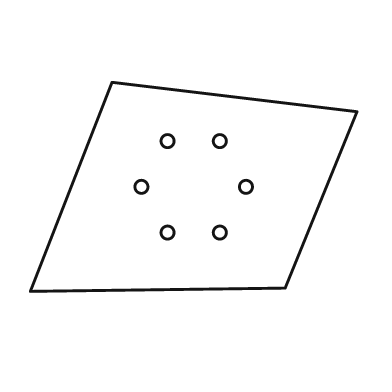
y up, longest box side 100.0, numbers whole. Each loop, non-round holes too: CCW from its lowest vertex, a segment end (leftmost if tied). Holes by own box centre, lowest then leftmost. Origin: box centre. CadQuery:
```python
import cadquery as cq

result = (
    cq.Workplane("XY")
    .moveTo(-50.0, -32.0)
    .lineTo(28.0, -31.0)
    .lineTo(50.0, 23.0)
    .lineTo(-25.0, 32.0)
    .close()
    .moveTo(-8.0, -14.0)
    .circle(2.0)
    .moveTo(8.0, -14.0)
    .circle(2.0)
    .moveTo(-16.0, 0.0)
    .circle(2.0)
    .moveTo(16.0, 0.0)
    .circle(2.0)
    .moveTo(-8.0, 14.0)
    .circle(2.0)
    .moveTo(8.0, 14.0)
    .circle(2.0)
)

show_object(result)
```